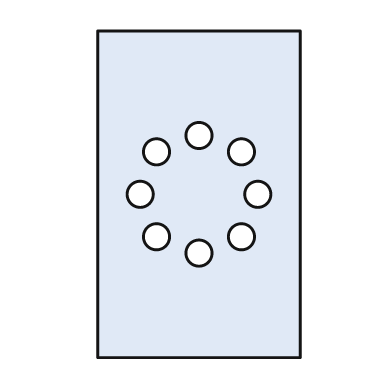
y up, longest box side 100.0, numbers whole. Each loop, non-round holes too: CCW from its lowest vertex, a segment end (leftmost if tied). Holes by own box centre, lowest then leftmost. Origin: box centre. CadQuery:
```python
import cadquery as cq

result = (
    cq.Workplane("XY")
    .moveTo(-31.0, -50.0)
    .lineTo(31.0, -50.0)
    .lineTo(31.0, 50.0)
    .lineTo(-31.0, 50.0)
    .close()
    .moveTo(0.0, -18.0)
    .circle(4.0)
    .moveTo(-13.0, -13.0)
    .circle(4.0)
    .moveTo(13.0, -13.0)
    .circle(4.0)
    .moveTo(-18.0, 0.0)
    .circle(4.0)
    .moveTo(18.0, 0.0)
    .circle(4.0)
    .moveTo(-13.0, 13.0)
    .circle(4.0)
    .moveTo(13.0, 13.0)
    .circle(4.0)
    .moveTo(0.0, 18.0)
    .circle(4.0)
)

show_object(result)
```